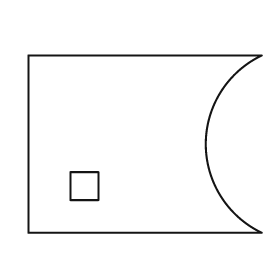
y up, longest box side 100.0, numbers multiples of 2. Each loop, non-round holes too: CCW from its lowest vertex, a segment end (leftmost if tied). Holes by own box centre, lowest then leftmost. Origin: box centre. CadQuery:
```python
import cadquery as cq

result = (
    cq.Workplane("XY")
    .moveTo(-50.0, -38.0)
    .lineTo(50.0, -38.0)
    .threePointArc((26.0, 0.0), (50.0, 38.0))
    .lineTo(-50.0, 38.0)
    .close()
    .moveTo(-32.0, -24.0)
    .lineTo(-20.0, -24.0)
    .lineTo(-20.0, -12.0)
    .lineTo(-32.0, -12.0)
    .close()
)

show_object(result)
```